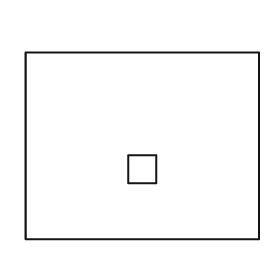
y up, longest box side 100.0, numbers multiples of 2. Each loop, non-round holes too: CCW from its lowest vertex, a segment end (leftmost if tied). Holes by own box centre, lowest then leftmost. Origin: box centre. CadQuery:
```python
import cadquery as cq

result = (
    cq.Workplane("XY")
    .moveTo(-50.0, -40.0)
    .lineTo(50.0, -40.0)
    .lineTo(50.0, 40.0)
    .lineTo(-50.0, 40.0)
    .close()
    .moveTo(-6.0, -16.0)
    .lineTo(6.0, -16.0)
    .lineTo(6.0, -4.0)
    .lineTo(-6.0, -4.0)
    .close()
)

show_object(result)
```